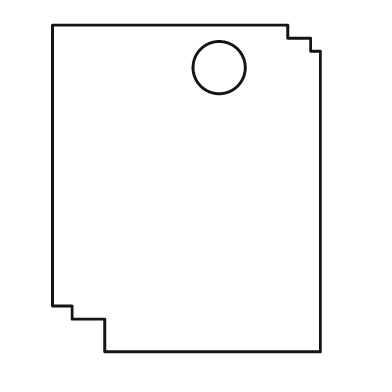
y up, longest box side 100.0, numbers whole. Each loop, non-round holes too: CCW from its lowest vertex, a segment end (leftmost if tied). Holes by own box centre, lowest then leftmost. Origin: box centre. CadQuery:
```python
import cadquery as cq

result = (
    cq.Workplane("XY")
    .moveTo(-25.0, -50.0)
    .lineTo(41.0, -50.0)
    .lineTo(41.0, 42.0)
    .lineTo(38.0, 42.0)
    .lineTo(38.0, 46.0)
    .lineTo(31.0, 46.0)
    .lineTo(31.0, 50.0)
    .lineTo(-41.0, 50.0)
    .lineTo(-41.0, -36.0)
    .lineTo(-35.0, -36.0)
    .lineTo(-35.0, -40.0)
    .lineTo(-25.0, -40.0)
    .close()
    .moveTo(10.0, 37.0)
    .circle(8.0)
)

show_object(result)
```